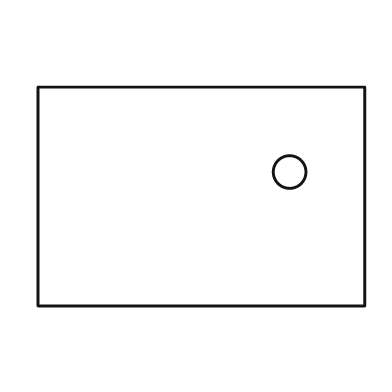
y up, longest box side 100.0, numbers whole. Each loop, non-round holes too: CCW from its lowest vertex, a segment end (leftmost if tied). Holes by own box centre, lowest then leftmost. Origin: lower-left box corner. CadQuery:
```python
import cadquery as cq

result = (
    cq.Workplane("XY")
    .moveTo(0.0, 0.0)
    .lineTo(100.0, 0.0)
    .lineTo(100.0, 67.0)
    .lineTo(0.0, 67.0)
    .close()
    .moveTo(77.0, 41.0)
    .circle(5.0)
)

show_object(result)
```